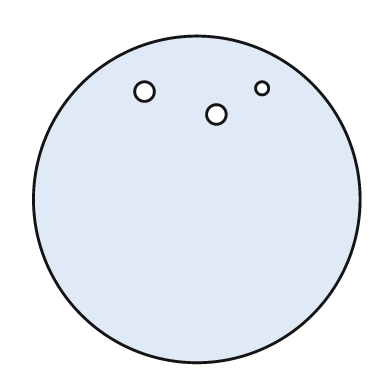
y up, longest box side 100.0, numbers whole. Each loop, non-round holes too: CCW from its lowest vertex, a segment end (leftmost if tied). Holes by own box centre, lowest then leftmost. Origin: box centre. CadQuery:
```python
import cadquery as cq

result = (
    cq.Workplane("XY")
    .moveTo(0.0, 0.0)
    .circle(50.0)
    .moveTo(6.0, 26.0)
    .circle(3.0)
    .moveTo(-16.0, 33.0)
    .circle(3.0)
    .moveTo(20.0, 34.0)
    .circle(2.0)
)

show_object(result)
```